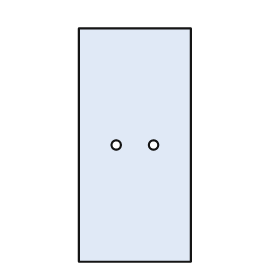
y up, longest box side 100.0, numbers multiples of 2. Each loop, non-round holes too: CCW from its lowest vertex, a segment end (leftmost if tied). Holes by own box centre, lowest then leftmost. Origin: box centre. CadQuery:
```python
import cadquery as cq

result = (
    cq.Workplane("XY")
    .moveTo(-24.0, -50.0)
    .lineTo(24.0, -50.0)
    .lineTo(24.0, 50.0)
    .lineTo(-24.0, 50.0)
    .close()
    .moveTo(-8.0, 0.0)
    .circle(2.0)
    .moveTo(8.0, 0.0)
    .circle(2.0)
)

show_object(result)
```